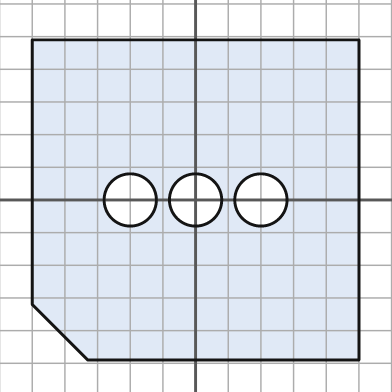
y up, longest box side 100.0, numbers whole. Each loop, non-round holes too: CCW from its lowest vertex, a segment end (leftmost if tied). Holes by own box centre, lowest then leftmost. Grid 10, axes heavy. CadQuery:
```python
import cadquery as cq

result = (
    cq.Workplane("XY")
    .moveTo(-33.0, -49.0)
    .lineTo(50.0, -49.0)
    .lineTo(50.0, 49.0)
    .lineTo(-50.0, 49.0)
    .lineTo(-50.0, -32.0)
    .close()
    .moveTo(-20.0, 0.0)
    .circle(8.0)
    .moveTo(0.0, 0.0)
    .circle(8.0)
    .moveTo(20.0, 0.0)
    .circle(8.0)
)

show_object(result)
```